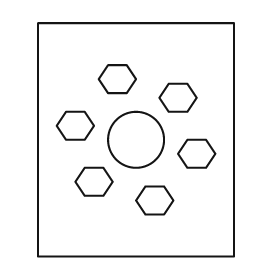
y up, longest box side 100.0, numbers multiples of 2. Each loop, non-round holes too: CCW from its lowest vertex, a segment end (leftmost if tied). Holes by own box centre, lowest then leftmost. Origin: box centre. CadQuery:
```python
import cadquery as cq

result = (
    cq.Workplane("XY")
    .moveTo(-42.0, -50.0)
    .lineTo(42.0, -50.0)
    .lineTo(42.0, 50.0)
    .lineTo(-42.0, 50.0)
    .close()
    .moveTo(4.0, -32.0)
    .lineTo(12.0, -32.0)
    .lineTo(16.0, -26.0)
    .lineTo(12.0, -20.0)
    .lineTo(4.0, -20.0)
    .lineTo(0.0, -26.0)
    .close()
    .moveTo(-22.0, -24.0)
    .lineTo(-14.0, -24.0)
    .lineTo(-10.0, -18.0)
    .lineTo(-14.0, -12.0)
    .lineTo(-22.0, -12.0)
    .lineTo(-26.0, -18.0)
    .close()
    .moveTo(22.0, -12.0)
    .lineTo(30.0, -12.0)
    .lineTo(34.0, -6.0)
    .lineTo(30.0, 0.0)
    .lineTo(22.0, 0.0)
    .lineTo(18.0, -6.0)
    .close()
    .moveTo(0.0, 0.0)
    .circle(12.0)
    .moveTo(-30.0, 0.0)
    .lineTo(-22.0, 0.0)
    .lineTo(-18.0, 6.0)
    .lineTo(-22.0, 12.0)
    .lineTo(-30.0, 12.0)
    .lineTo(-34.0, 6.0)
    .close()
    .moveTo(14.0, 12.0)
    .lineTo(22.0, 12.0)
    .lineTo(26.0, 18.0)
    .lineTo(22.0, 24.0)
    .lineTo(14.0, 24.0)
    .lineTo(10.0, 18.0)
    .close()
    .moveTo(-12.0, 20.0)
    .lineTo(-4.0, 20.0)
    .lineTo(0.0, 26.0)
    .lineTo(-4.0, 32.0)
    .lineTo(-12.0, 32.0)
    .lineTo(-16.0, 26.0)
    .close()
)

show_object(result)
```